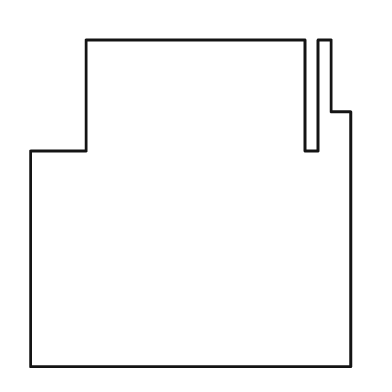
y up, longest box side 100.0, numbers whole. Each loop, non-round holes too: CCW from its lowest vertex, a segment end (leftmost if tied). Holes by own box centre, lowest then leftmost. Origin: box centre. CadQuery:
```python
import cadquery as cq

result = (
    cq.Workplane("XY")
    .moveTo(-49.0, -50.0)
    .lineTo(49.0, -50.0)
    .lineTo(49.0, 28.0)
    .lineTo(43.0, 28.0)
    .lineTo(43.0, 50.0)
    .lineTo(39.0, 50.0)
    .lineTo(39.0, 16.0)
    .lineTo(35.0, 16.0)
    .lineTo(35.0, 50.0)
    .lineTo(-32.0, 50.0)
    .lineTo(-32.0, 16.0)
    .lineTo(-49.0, 16.0)
    .close()
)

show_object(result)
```